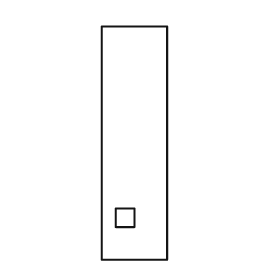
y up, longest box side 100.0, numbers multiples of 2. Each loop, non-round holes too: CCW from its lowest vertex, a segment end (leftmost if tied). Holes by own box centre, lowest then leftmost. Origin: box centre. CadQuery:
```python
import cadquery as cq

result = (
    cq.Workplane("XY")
    .moveTo(-14.0, -50.0)
    .lineTo(14.0, -50.0)
    .lineTo(14.0, 50.0)
    .lineTo(-14.0, 50.0)
    .close()
    .moveTo(-8.0, -36.0)
    .lineTo(0.0, -36.0)
    .lineTo(0.0, -28.0)
    .lineTo(-8.0, -28.0)
    .close()
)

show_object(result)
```